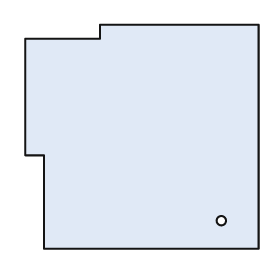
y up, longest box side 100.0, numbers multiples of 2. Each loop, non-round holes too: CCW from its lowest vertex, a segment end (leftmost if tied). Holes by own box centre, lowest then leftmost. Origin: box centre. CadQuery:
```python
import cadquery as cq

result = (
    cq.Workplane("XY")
    .moveTo(-42.0, -48.0)
    .lineTo(50.0, -48.0)
    .lineTo(50.0, 48.0)
    .lineTo(-18.0, 48.0)
    .lineTo(-18.0, 42.0)
    .lineTo(-50.0, 42.0)
    .lineTo(-50.0, -8.0)
    .lineTo(-42.0, -8.0)
    .close()
    .moveTo(34.0, -36.0)
    .circle(2.0)
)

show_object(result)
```